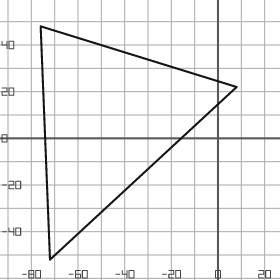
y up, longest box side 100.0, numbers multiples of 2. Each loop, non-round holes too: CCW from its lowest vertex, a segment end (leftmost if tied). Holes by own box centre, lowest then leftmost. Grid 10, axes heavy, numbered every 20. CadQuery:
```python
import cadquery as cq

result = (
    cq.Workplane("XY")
    .moveTo(-72.0, -52.0)
    .lineTo(8.0, 22.0)
    .lineTo(-76.0, 48.0)
    .close()
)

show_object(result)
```